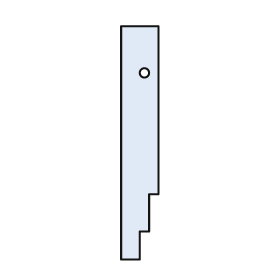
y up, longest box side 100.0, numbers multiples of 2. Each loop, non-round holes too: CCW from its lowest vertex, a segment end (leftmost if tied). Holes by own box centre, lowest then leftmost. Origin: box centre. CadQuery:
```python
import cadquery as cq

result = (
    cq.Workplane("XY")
    .moveTo(-8.0, -50.0)
    .lineTo(0.0, -50.0)
    .lineTo(0.0, -38.0)
    .lineTo(4.0, -38.0)
    .lineTo(4.0, -22.0)
    .lineTo(8.0, -22.0)
    .lineTo(8.0, 50.0)
    .lineTo(-8.0, 50.0)
    .close()
    .moveTo(2.0, 30.0)
    .circle(2.0)
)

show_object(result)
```